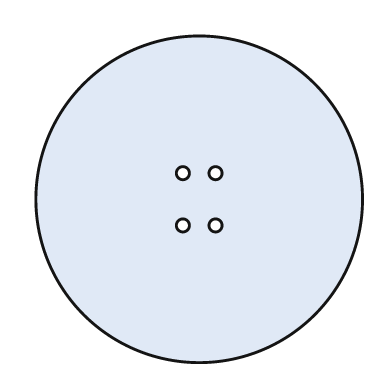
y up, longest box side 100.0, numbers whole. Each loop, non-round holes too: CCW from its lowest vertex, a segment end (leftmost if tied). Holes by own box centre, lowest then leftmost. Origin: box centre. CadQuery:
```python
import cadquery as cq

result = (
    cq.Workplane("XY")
    .moveTo(0.0, 0.0)
    .circle(50.0)
    .moveTo(-5.0, -8.0)
    .circle(2.0)
    .moveTo(5.0, -8.0)
    .circle(2.0)
    .moveTo(-5.0, 8.0)
    .circle(2.0)
    .moveTo(5.0, 8.0)
    .circle(2.0)
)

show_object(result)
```